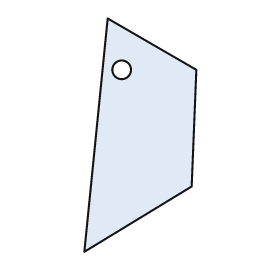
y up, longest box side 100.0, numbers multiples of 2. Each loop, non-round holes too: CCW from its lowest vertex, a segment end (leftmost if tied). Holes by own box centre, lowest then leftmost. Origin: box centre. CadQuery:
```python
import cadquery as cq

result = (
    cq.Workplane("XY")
    .moveTo(-24.0, -50.0)
    .lineTo(22.0, -22.0)
    .lineTo(24.0, 28.0)
    .lineTo(-14.0, 50.0)
    .close()
    .moveTo(-8.0, 28.0)
    .circle(4.0)
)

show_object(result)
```